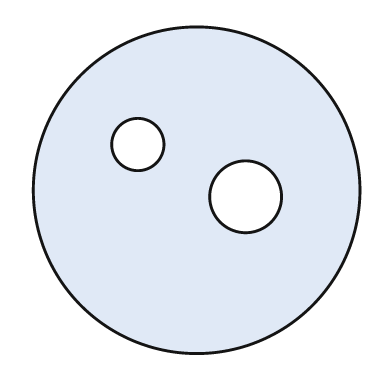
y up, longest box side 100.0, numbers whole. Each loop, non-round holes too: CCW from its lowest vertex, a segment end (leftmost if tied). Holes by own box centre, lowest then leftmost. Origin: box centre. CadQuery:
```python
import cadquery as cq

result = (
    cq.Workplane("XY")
    .moveTo(0.0, 0.0)
    .circle(50.0)
    .moveTo(15.0, -2.0)
    .circle(11.0)
    .moveTo(-18.0, 14.0)
    .circle(8.0)
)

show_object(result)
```